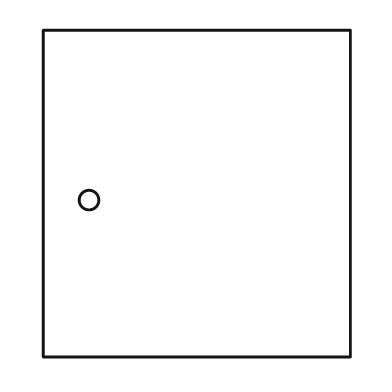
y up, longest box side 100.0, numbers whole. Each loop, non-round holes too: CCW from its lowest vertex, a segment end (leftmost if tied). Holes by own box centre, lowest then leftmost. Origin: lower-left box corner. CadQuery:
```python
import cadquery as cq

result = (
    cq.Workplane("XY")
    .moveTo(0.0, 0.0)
    .lineTo(94.0, 0.0)
    .lineTo(94.0, 100.0)
    .lineTo(0.0, 100.0)
    .close()
    .moveTo(14.0, 48.0)
    .circle(3.0)
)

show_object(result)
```